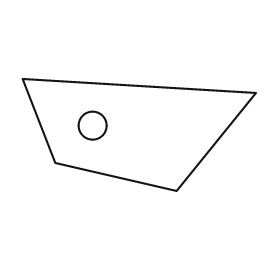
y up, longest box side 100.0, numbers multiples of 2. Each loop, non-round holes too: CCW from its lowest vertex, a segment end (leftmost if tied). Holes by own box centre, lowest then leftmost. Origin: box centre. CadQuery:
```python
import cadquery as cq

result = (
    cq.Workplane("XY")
    .moveTo(16.0, -24.0)
    .lineTo(50.0, 18.0)
    .lineTo(-50.0, 24.0)
    .lineTo(-36.0, -12.0)
    .close()
    .moveTo(-20.0, 4.0)
    .circle(6.0)
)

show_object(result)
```